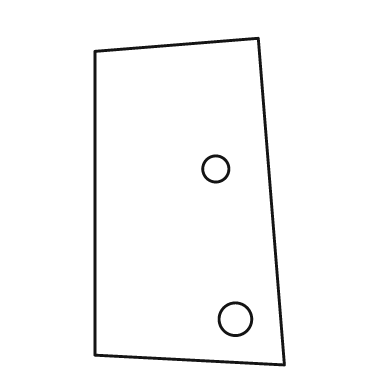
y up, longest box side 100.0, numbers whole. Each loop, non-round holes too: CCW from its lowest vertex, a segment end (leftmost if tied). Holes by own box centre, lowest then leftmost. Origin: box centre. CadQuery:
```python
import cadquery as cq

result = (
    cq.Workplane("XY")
    .moveTo(29.0, -50.0)
    .lineTo(21.0, 50.0)
    .lineTo(-29.0, 46.0)
    .lineTo(-29.0, -47.0)
    .close()
    .moveTo(14.0, -36.0)
    .circle(5.0)
    .moveTo(8.0, 10.0)
    .circle(4.0)
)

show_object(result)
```